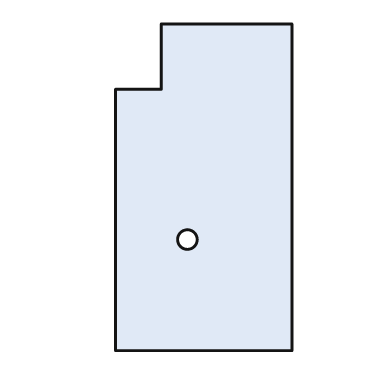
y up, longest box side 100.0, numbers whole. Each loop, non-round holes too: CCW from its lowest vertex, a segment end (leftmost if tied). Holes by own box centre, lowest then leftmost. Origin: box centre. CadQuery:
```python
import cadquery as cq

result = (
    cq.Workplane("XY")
    .moveTo(-27.0, -50.0)
    .lineTo(27.0, -50.0)
    .lineTo(27.0, 50.0)
    .lineTo(-13.0, 50.0)
    .lineTo(-13.0, 30.0)
    .lineTo(-27.0, 30.0)
    .close()
    .moveTo(-5.0, -16.0)
    .circle(3.0)
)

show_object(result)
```